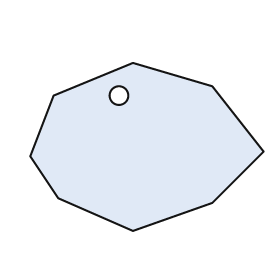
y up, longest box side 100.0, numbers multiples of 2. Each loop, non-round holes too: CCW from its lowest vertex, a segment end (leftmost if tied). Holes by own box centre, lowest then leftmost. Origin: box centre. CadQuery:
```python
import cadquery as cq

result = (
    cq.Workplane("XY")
    .moveTo(-6.0, -36.0)
    .lineTo(28.0, -24.0)
    .lineTo(50.0, -2.0)
    .lineTo(28.0, 26.0)
    .lineTo(-6.0, 36.0)
    .lineTo(-40.0, 22.0)
    .lineTo(-50.0, -4.0)
    .lineTo(-38.0, -22.0)
    .close()
    .moveTo(-12.0, 22.0)
    .circle(4.0)
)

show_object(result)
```